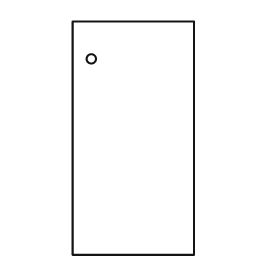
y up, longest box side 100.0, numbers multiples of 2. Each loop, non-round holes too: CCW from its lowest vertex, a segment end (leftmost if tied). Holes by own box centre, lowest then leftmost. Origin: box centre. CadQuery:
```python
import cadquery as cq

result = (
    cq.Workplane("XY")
    .moveTo(-26.0, -50.0)
    .lineTo(26.0, -50.0)
    .lineTo(26.0, 50.0)
    .lineTo(-26.0, 50.0)
    .close()
    .moveTo(-18.0, 34.0)
    .circle(2.0)
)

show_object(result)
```